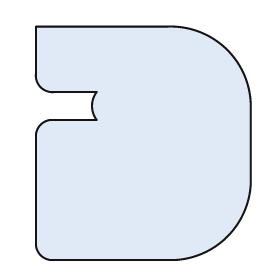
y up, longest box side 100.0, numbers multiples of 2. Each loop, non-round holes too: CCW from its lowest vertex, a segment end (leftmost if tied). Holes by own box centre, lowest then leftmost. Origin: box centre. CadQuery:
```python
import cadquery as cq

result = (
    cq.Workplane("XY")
    .moveTo(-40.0, -50.0)
    .lineTo(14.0, -50.0)
    .threePointArc((36.0, -40.0), (46.0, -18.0))
    .lineTo(46.0, 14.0)
    .threePointArc((36.0, 40.0), (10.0, 50.0))
    .lineTo(-46.0, 50.0)
    .lineTo(-46.0, 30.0)
    .threePointArc((-44.0, 24.0), (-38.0, 22.0))
    .lineTo(-20.0, 22.0)
    .threePointArc((-22.0, 16.0), (-20.0, 10.0))
    .lineTo(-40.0, 10.0)
    .threePointArc((-44.0, 8.0), (-46.0, 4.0))
    .lineTo(-46.0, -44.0)
    .threePointArc((-44.0, -48.0), (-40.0, -50.0))
    .close()
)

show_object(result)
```